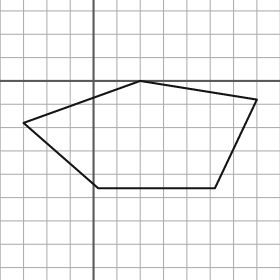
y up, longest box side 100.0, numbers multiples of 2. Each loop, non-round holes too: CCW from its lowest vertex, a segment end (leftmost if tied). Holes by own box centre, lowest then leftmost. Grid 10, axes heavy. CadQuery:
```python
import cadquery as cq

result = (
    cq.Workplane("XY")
    .moveTo(2.0, -46.0)
    .lineTo(52.0, -46.0)
    .lineTo(70.0, -8.0)
    .lineTo(20.0, 0.0)
    .lineTo(-30.0, -18.0)
    .close()
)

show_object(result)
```